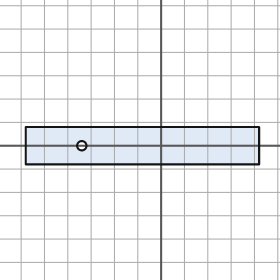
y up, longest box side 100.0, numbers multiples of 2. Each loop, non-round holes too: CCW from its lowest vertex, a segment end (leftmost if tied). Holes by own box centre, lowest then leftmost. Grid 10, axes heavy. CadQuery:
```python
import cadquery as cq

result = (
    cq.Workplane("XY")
    .moveTo(-58.0, -8.0)
    .lineTo(42.0, -8.0)
    .lineTo(42.0, 8.0)
    .lineTo(-58.0, 8.0)
    .close()
    .moveTo(-34.0, 0.0)
    .circle(2.0)
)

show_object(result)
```